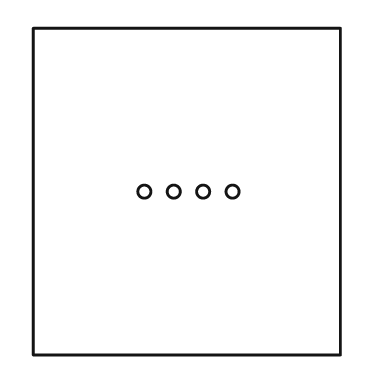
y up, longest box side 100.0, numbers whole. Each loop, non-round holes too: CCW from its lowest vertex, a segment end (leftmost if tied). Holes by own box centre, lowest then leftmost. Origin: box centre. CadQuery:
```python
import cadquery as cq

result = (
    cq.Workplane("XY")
    .moveTo(-47.0, -50.0)
    .lineTo(47.0, -50.0)
    .lineTo(47.0, 50.0)
    .lineTo(-47.0, 50.0)
    .close()
    .moveTo(-13.0, 0.0)
    .circle(2.0)
    .moveTo(-4.0, 0.0)
    .circle(2.0)
    .moveTo(5.0, 0.0)
    .circle(2.0)
    .moveTo(14.0, 0.0)
    .circle(2.0)
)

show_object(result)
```